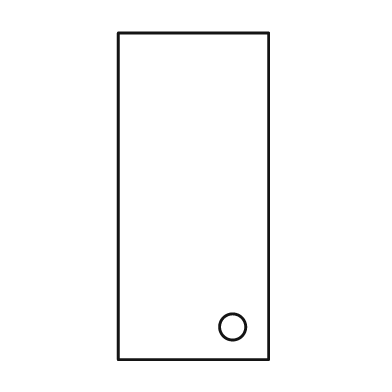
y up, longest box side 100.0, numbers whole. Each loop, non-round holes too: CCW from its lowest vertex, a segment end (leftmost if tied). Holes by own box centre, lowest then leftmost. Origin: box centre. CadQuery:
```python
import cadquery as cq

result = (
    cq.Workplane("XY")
    .moveTo(-23.0, -50.0)
    .lineTo(23.0, -50.0)
    .lineTo(23.0, 50.0)
    .lineTo(-23.0, 50.0)
    .close()
    .moveTo(12.0, -40.0)
    .circle(4.0)
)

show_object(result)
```